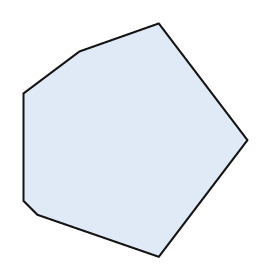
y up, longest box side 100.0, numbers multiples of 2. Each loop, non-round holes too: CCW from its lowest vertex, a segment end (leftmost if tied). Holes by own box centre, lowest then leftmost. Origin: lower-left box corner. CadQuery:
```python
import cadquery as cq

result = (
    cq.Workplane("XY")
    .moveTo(58.0, 0.0)
    .lineTo(96.0, 50.0)
    .lineTo(58.0, 100.0)
    .lineTo(24.0, 88.0)
    .lineTo(0.0, 70.0)
    .lineTo(0.0, 24.0)
    .lineTo(6.0, 18.0)
    .close()
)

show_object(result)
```